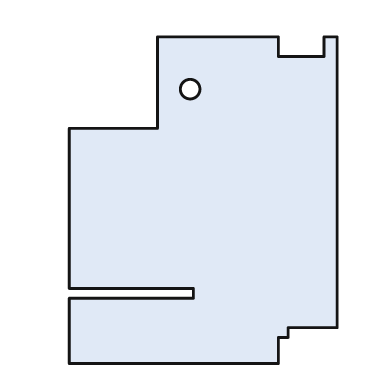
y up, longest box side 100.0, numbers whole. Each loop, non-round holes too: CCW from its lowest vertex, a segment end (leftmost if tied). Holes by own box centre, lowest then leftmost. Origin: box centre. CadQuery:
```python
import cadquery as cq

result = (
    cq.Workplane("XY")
    .moveTo(-41.0, -50.0)
    .lineTo(23.0, -50.0)
    .lineTo(23.0, -42.0)
    .lineTo(26.0, -42.0)
    .lineTo(26.0, -39.0)
    .lineTo(41.0, -39.0)
    .lineTo(41.0, 50.0)
    .lineTo(37.0, 50.0)
    .lineTo(37.0, 44.0)
    .lineTo(23.0, 44.0)
    .lineTo(23.0, 50.0)
    .lineTo(-14.0, 50.0)
    .lineTo(-14.0, 22.0)
    .lineTo(-41.0, 22.0)
    .lineTo(-41.0, -27.0)
    .lineTo(-3.0, -27.0)
    .lineTo(-3.0, -30.0)
    .lineTo(-41.0, -30.0)
    .close()
    .moveTo(-4.0, 34.0)
    .circle(3.0)
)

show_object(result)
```